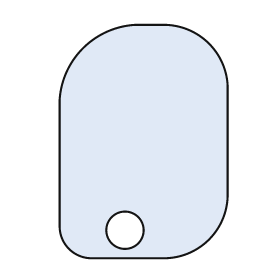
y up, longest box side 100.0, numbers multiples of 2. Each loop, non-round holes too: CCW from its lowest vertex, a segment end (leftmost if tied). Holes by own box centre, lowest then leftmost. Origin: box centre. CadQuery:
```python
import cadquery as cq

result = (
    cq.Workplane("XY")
    .moveTo(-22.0, -50.0)
    .lineTo(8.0, -50.0)
    .threePointArc((28.0, -42.0), (36.0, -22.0))
    .lineTo(36.0, 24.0)
    .threePointArc((28.0, 42.0), (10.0, 50.0))
    .lineTo(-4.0, 50.0)
    .threePointArc((-26.0, 40.0), (-36.0, 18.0))
    .lineTo(-36.0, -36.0)
    .threePointArc((-32.0, -46.0), (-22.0, -50.0))
    .close()
    .moveTo(-8.0, -38.0)
    .circle(8.0)
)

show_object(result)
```